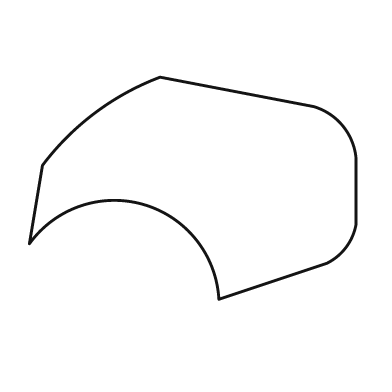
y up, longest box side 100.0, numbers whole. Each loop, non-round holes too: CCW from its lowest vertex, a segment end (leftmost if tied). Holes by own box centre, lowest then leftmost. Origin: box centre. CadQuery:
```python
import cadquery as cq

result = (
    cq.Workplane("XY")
    .moveTo(8.0, -34.0)
    .lineTo(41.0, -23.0)
    .threePointArc((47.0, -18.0), (50.0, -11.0))
    .lineTo(50.0, 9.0)
    .threePointArc((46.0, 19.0), (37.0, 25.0))
    .lineTo(-10.0, 34.0)
    .threePointArc((-30.0, 23.0), (-46.0, 7.0))
    .lineTo(-50.0, -17.0)
    .threePointArc((-15.0, -5.0), (8.0, -34.0))
    .close()
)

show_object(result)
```